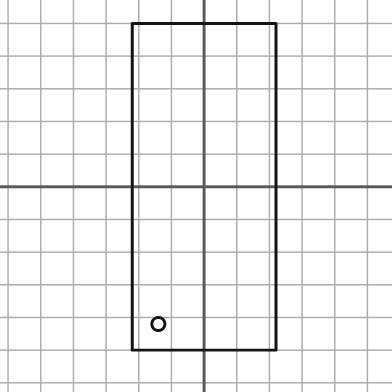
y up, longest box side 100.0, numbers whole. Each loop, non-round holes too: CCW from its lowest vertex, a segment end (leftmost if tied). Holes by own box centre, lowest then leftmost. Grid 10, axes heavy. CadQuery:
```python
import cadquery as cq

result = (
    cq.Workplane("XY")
    .moveTo(-22.0, -50.0)
    .lineTo(22.0, -50.0)
    .lineTo(22.0, 50.0)
    .lineTo(-22.0, 50.0)
    .close()
    .moveTo(-14.0, -42.0)
    .circle(2.0)
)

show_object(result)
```